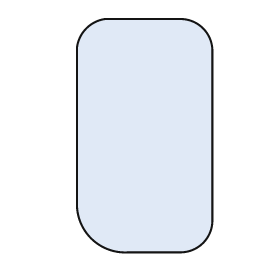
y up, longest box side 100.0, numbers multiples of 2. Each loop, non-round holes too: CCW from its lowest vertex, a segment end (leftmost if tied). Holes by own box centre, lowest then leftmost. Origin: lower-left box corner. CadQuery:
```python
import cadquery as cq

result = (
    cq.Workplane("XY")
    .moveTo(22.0, 0.0)
    .lineTo(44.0, 0.0)
    .threePointArc((54.0, 4.0), (58.0, 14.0))
    .lineTo(58.0, 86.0)
    .threePointArc((54.0, 96.0), (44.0, 100.0))
    .lineTo(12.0, 100.0)
    .threePointArc((4.0, 96.0), (0.0, 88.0))
    .lineTo(0.0, 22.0)
    .threePointArc((6.0, 6.0), (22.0, 0.0))
    .close()
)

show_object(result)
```